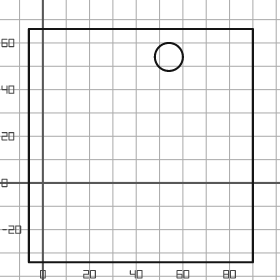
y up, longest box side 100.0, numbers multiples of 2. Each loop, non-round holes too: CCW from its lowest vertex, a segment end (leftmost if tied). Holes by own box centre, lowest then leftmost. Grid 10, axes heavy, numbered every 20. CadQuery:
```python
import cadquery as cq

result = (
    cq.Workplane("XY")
    .moveTo(-6.0, -34.0)
    .lineTo(90.0, -34.0)
    .lineTo(90.0, 66.0)
    .lineTo(-6.0, 66.0)
    .close()
    .moveTo(54.0, 54.0)
    .circle(6.0)
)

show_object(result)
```